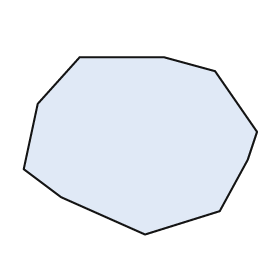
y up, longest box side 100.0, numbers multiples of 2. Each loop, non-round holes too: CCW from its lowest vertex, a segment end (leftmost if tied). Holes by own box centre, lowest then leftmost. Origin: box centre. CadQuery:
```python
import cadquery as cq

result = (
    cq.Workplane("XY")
    .moveTo(2.0, -38.0)
    .lineTo(34.0, -28.0)
    .lineTo(46.0, -6.0)
    .lineTo(50.0, 6.0)
    .lineTo(32.0, 32.0)
    .lineTo(10.0, 38.0)
    .lineTo(-26.0, 38.0)
    .lineTo(-44.0, 18.0)
    .lineTo(-50.0, -10.0)
    .lineTo(-34.0, -22.0)
    .close()
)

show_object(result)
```